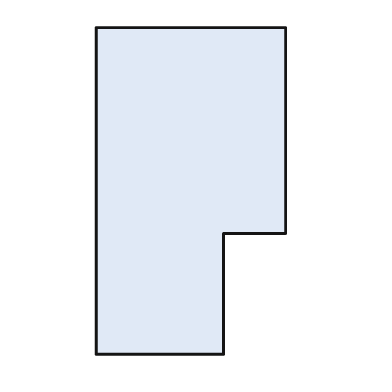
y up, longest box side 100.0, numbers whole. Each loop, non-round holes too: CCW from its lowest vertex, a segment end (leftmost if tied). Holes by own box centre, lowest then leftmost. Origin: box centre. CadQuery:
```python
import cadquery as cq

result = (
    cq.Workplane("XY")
    .moveTo(-29.0, -50.0)
    .lineTo(10.0, -50.0)
    .lineTo(10.0, -13.0)
    .lineTo(29.0, -13.0)
    .lineTo(29.0, 50.0)
    .lineTo(-29.0, 50.0)
    .close()
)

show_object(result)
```